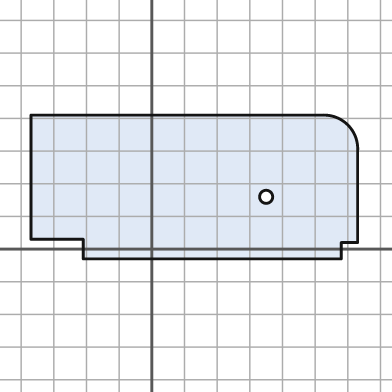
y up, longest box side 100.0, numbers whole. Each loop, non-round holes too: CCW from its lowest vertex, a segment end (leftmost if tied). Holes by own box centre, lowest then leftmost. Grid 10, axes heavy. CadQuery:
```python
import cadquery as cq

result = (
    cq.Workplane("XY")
    .moveTo(-21.0, -3.0)
    .lineTo(58.0, -3.0)
    .lineTo(58.0, 2.0)
    .lineTo(63.0, 2.0)
    .lineTo(63.0, 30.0)
    .threePointArc((60.0, 38.0), (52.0, 41.0))
    .lineTo(-37.0, 41.0)
    .lineTo(-37.0, 3.0)
    .lineTo(-21.0, 3.0)
    .close()
    .moveTo(35.0, 16.0)
    .circle(2.0)
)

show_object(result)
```